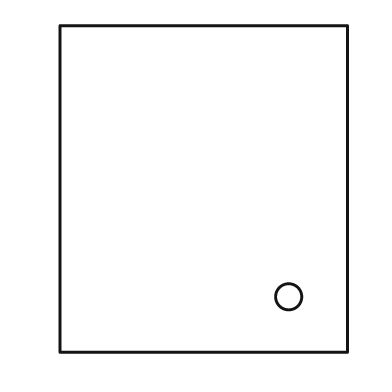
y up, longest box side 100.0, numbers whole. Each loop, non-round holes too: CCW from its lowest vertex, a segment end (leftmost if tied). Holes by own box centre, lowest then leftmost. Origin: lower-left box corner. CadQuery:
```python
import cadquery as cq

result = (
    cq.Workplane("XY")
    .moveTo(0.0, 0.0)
    .lineTo(88.0, 0.0)
    .lineTo(88.0, 100.0)
    .lineTo(0.0, 100.0)
    .close()
    .moveTo(70.0, 17.0)
    .circle(4.0)
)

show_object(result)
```